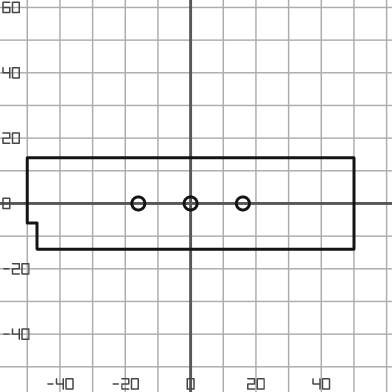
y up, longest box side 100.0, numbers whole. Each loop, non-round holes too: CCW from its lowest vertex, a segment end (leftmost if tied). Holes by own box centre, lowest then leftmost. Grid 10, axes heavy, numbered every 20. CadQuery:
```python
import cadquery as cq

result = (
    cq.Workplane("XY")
    .moveTo(-47.0, -14.0)
    .lineTo(50.0, -14.0)
    .lineTo(50.0, 14.0)
    .lineTo(-50.0, 14.0)
    .lineTo(-50.0, -6.0)
    .lineTo(-47.0, -6.0)
    .close()
    .moveTo(-16.0, 0.0)
    .circle(2.0)
    .moveTo(0.0, 0.0)
    .circle(2.0)
    .moveTo(16.0, 0.0)
    .circle(2.0)
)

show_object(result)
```